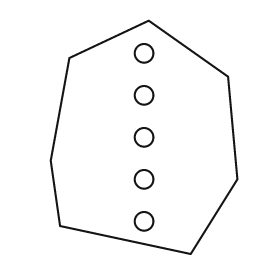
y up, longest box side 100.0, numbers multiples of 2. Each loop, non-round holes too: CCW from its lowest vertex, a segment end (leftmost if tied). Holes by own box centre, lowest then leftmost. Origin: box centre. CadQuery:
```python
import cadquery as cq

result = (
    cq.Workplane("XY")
    .moveTo(20.0, -50.0)
    .lineTo(40.0, -18.0)
    .lineTo(36.0, 26.0)
    .lineTo(2.0, 50.0)
    .lineTo(-32.0, 34.0)
    .lineTo(-40.0, -10.0)
    .lineTo(-36.0, -38.0)
    .close()
    .moveTo(0.0, -36.0)
    .circle(4.0)
    .moveTo(0.0, -18.0)
    .circle(4.0)
    .moveTo(0.0, 0.0)
    .circle(4.0)
    .moveTo(0.0, 18.0)
    .circle(4.0)
    .moveTo(0.0, 36.0)
    .circle(4.0)
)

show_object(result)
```